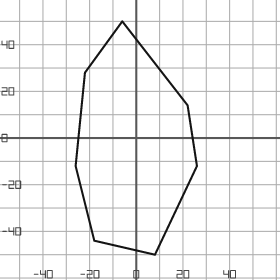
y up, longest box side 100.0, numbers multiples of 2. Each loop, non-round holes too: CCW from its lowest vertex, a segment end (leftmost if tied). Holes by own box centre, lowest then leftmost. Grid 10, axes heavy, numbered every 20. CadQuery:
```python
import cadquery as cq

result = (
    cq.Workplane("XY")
    .moveTo(8.0, -50.0)
    .lineTo(26.0, -12.0)
    .lineTo(22.0, 14.0)
    .lineTo(-6.0, 50.0)
    .lineTo(-22.0, 28.0)
    .lineTo(-26.0, -12.0)
    .lineTo(-18.0, -44.0)
    .close()
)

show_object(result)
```